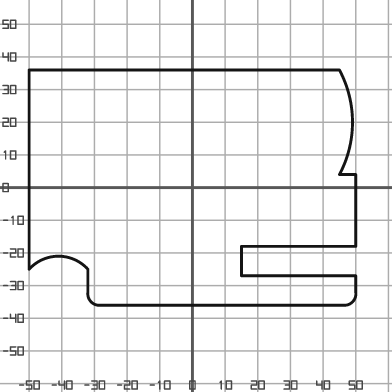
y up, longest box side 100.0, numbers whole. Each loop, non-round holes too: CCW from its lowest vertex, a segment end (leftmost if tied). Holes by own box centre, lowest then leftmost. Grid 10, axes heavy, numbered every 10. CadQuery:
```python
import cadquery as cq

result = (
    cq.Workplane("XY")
    .moveTo(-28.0, -36.0)
    .lineTo(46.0, -36.0)
    .threePointArc((49.0, -35.0), (50.0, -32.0))
    .lineTo(50.0, -27.0)
    .lineTo(15.0, -27.0)
    .lineTo(15.0, -18.0)
    .lineTo(50.0, -18.0)
    .lineTo(50.0, 4.0)
    .lineTo(45.0, 4.0)
    .threePointArc((49.0, 20.0), (45.0, 36.0))
    .lineTo(-50.0, 36.0)
    .lineTo(-50.0, -25.0)
    .threePointArc((-41.0, -21.0), (-32.0, -25.0))
    .lineTo(-32.0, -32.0)
    .threePointArc((-31.0, -35.0), (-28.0, -36.0))
    .close()
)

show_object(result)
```